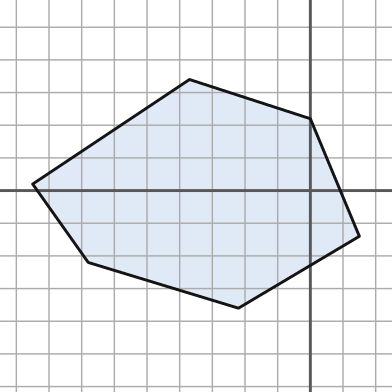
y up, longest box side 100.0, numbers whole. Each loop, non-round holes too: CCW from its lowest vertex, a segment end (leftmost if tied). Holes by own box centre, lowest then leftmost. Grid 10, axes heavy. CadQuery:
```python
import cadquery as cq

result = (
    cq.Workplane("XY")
    .moveTo(-22.0, -36.0)
    .lineTo(15.0, -14.0)
    .lineTo(0.0, 22.0)
    .lineTo(-37.0, 34.0)
    .lineTo(-85.0, 2.0)
    .lineTo(-68.0, -22.0)
    .close()
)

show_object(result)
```